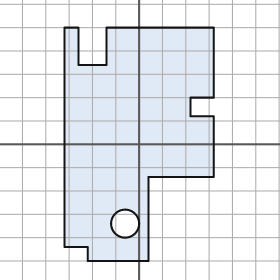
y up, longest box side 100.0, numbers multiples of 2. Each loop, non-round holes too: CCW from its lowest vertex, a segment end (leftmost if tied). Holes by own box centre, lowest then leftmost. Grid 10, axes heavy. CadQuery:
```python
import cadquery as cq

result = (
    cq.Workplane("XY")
    .moveTo(-22.0, -50.0)
    .lineTo(4.0, -50.0)
    .lineTo(4.0, -14.0)
    .lineTo(32.0, -14.0)
    .lineTo(32.0, 12.0)
    .lineTo(22.0, 12.0)
    .lineTo(22.0, 20.0)
    .lineTo(32.0, 20.0)
    .lineTo(32.0, 50.0)
    .lineTo(-14.0, 50.0)
    .lineTo(-14.0, 34.0)
    .lineTo(-26.0, 34.0)
    .lineTo(-26.0, 50.0)
    .lineTo(-32.0, 50.0)
    .lineTo(-32.0, -44.0)
    .lineTo(-22.0, -44.0)
    .close()
    .moveTo(-6.0, -34.0)
    .circle(6.0)
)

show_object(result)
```